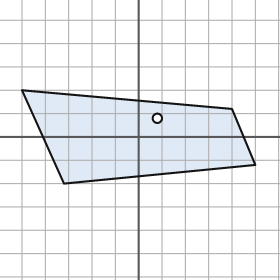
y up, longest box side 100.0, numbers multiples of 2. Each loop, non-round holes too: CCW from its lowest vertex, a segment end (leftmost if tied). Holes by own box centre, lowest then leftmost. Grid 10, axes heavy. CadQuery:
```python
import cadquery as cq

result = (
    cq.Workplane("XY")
    .moveTo(-32.0, -20.0)
    .lineTo(50.0, -12.0)
    .lineTo(40.0, 12.0)
    .lineTo(-50.0, 20.0)
    .close()
    .moveTo(8.0, 8.0)
    .circle(2.0)
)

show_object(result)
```